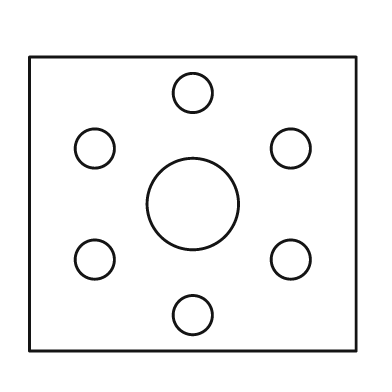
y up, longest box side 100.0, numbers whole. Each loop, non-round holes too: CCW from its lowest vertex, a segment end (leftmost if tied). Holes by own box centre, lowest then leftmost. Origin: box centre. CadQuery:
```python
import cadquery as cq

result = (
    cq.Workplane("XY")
    .moveTo(-50.0, -45.0)
    .lineTo(50.0, -45.0)
    .lineTo(50.0, 45.0)
    .lineTo(-50.0, 45.0)
    .close()
    .moveTo(0.0, -34.0)
    .circle(6.0)
    .moveTo(-30.0, -17.0)
    .circle(6.0)
    .moveTo(30.0, -17.0)
    .circle(6.0)
    .moveTo(0.0, 0.0)
    .circle(14.0)
    .moveTo(-30.0, 17.0)
    .circle(6.0)
    .moveTo(30.0, 17.0)
    .circle(6.0)
    .moveTo(0.0, 34.0)
    .circle(6.0)
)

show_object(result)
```